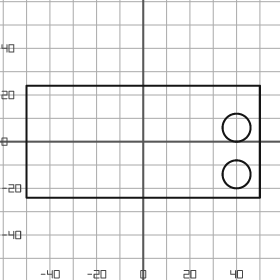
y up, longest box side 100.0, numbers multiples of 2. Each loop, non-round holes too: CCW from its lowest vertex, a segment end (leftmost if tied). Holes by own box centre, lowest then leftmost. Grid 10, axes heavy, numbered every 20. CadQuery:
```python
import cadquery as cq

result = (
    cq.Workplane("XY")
    .moveTo(-50.0, -24.0)
    .lineTo(50.0, -24.0)
    .lineTo(50.0, 24.0)
    .lineTo(-50.0, 24.0)
    .close()
    .moveTo(40.0, -14.0)
    .circle(6.0)
    .moveTo(40.0, 6.0)
    .circle(6.0)
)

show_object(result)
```